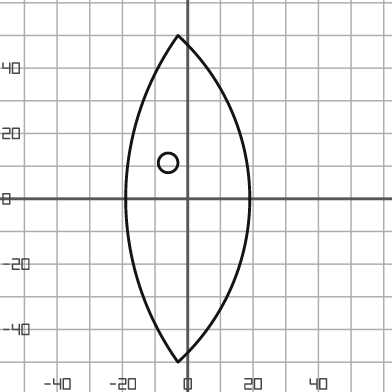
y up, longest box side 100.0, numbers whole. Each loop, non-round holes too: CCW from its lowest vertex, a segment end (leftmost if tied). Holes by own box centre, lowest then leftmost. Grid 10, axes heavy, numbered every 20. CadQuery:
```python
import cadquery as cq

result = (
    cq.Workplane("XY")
    .moveTo(-3.0, -50.0)
    .threePointArc((19.0, 0.0), (-3.0, 50.0))
    .threePointArc((-19.0, 0.0), (-3.0, -50.0))
    .close()
    .moveTo(-6.0, 11.0)
    .circle(3.0)
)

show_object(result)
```